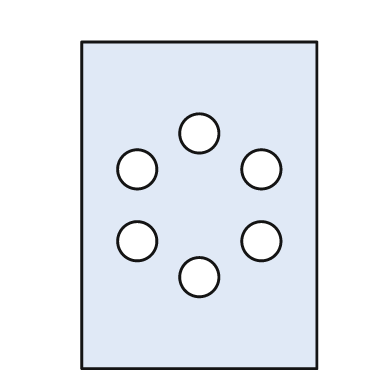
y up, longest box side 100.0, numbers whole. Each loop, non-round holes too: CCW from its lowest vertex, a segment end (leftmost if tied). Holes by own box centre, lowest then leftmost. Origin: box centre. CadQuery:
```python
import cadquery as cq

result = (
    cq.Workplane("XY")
    .moveTo(-36.0, -50.0)
    .lineTo(36.0, -50.0)
    .lineTo(36.0, 50.0)
    .lineTo(-36.0, 50.0)
    .close()
    .moveTo(0.0, -22.0)
    .circle(6.0)
    .moveTo(-19.0, -11.0)
    .circle(6.0)
    .moveTo(19.0, -11.0)
    .circle(6.0)
    .moveTo(-19.0, 11.0)
    .circle(6.0)
    .moveTo(19.0, 11.0)
    .circle(6.0)
    .moveTo(0.0, 22.0)
    .circle(6.0)
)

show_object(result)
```